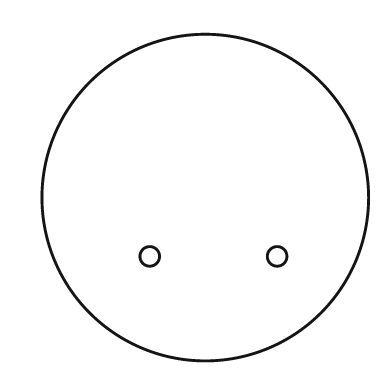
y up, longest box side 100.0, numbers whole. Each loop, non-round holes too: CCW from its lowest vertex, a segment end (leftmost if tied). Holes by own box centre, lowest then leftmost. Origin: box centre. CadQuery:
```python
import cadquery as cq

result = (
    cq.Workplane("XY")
    .moveTo(0.0, 0.0)
    .circle(50.0)
    .moveTo(-17.0, -18.0)
    .circle(3.0)
    .moveTo(22.0, -18.0)
    .circle(3.0)
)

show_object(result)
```